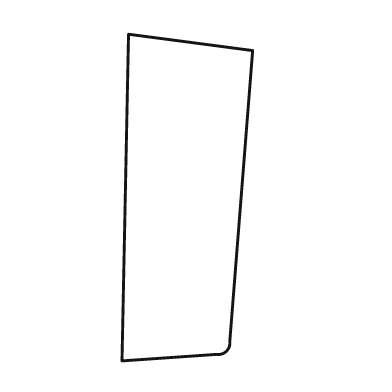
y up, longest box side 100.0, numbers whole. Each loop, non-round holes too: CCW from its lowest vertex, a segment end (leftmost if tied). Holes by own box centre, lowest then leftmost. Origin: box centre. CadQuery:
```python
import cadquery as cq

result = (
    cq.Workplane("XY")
    .moveTo(-20.0, -50.0)
    .lineTo(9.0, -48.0)
    .threePointArc((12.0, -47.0), (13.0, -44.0))
    .lineTo(20.0, 45.0)
    .lineTo(-18.0, 50.0)
    .close()
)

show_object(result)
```